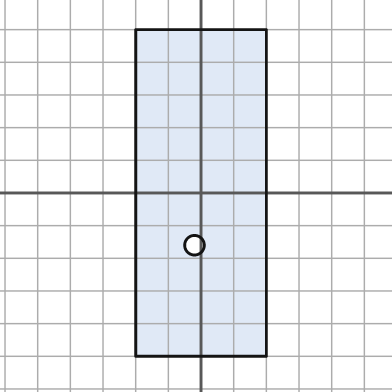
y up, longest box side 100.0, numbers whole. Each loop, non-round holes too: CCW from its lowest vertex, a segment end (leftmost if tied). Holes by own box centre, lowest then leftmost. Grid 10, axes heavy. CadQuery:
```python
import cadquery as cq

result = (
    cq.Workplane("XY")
    .moveTo(-20.0, -50.0)
    .lineTo(20.0, -50.0)
    .lineTo(20.0, 50.0)
    .lineTo(-20.0, 50.0)
    .close()
    .moveTo(-2.0, -16.0)
    .circle(3.0)
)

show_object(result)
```